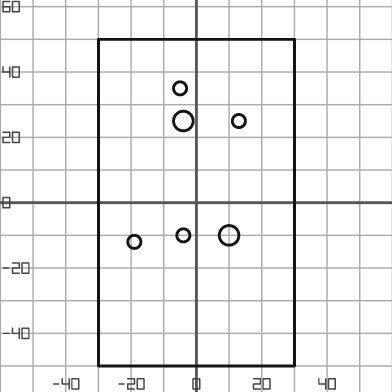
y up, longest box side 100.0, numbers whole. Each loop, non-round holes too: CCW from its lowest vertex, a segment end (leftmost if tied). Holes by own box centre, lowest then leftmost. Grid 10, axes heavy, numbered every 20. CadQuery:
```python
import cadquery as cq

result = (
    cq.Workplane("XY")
    .moveTo(-30.0, -50.0)
    .lineTo(30.0, -50.0)
    .lineTo(30.0, 50.0)
    .lineTo(-30.0, 50.0)
    .close()
    .moveTo(-19.0, -12.0)
    .circle(2.0)
    .moveTo(-4.0, -10.0)
    .circle(2.0)
    .moveTo(10.0, -10.0)
    .circle(3.0)
    .moveTo(-4.0, 25.0)
    .circle(3.0)
    .moveTo(13.0, 25.0)
    .circle(2.0)
    .moveTo(-5.0, 35.0)
    .circle(2.0)
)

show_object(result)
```